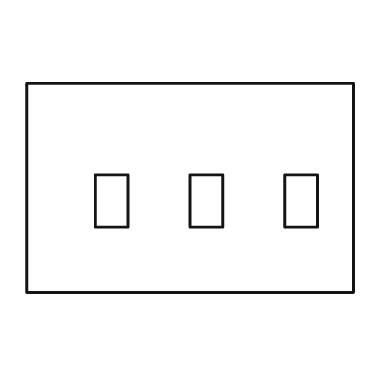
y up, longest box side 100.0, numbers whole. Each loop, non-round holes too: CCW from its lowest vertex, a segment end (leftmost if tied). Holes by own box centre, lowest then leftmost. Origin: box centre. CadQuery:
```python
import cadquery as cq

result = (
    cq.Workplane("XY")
    .moveTo(-50.0, -32.0)
    .lineTo(50.0, -32.0)
    .lineTo(50.0, 32.0)
    .lineTo(-50.0, 32.0)
    .close()
    .moveTo(-29.0, -12.0)
    .lineTo(-19.0, -12.0)
    .lineTo(-19.0, 4.0)
    .lineTo(-29.0, 4.0)
    .close()
    .moveTo(0.0, -12.0)
    .lineTo(10.0, -12.0)
    .lineTo(10.0, 4.0)
    .lineTo(0.0, 4.0)
    .close()
    .moveTo(29.0, -12.0)
    .lineTo(39.0, -12.0)
    .lineTo(39.0, 4.0)
    .lineTo(29.0, 4.0)
    .close()
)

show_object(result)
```